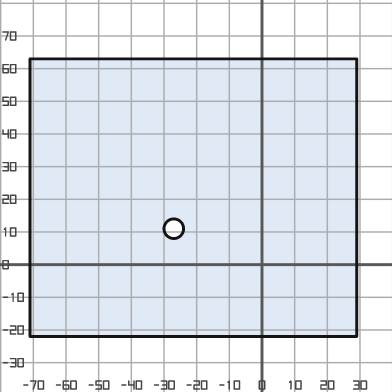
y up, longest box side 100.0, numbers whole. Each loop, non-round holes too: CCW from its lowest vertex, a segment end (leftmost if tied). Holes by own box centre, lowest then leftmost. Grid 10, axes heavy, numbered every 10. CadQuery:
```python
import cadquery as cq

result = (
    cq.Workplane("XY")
    .moveTo(-71.0, -22.0)
    .lineTo(29.0, -22.0)
    .lineTo(29.0, 63.0)
    .lineTo(-71.0, 63.0)
    .close()
    .moveTo(-27.0, 11.0)
    .circle(3.0)
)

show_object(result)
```